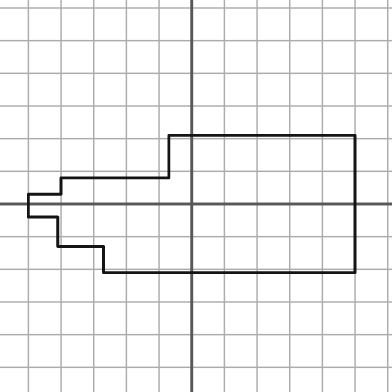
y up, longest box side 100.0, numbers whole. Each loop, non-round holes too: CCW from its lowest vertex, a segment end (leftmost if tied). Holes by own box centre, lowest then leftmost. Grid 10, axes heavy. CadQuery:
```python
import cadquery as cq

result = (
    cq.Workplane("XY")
    .moveTo(-27.0, -21.0)
    .lineTo(50.0, -21.0)
    .lineTo(50.0, 21.0)
    .lineTo(-7.0, 21.0)
    .lineTo(-7.0, 8.0)
    .lineTo(-40.0, 8.0)
    .lineTo(-40.0, 3.0)
    .lineTo(-50.0, 3.0)
    .lineTo(-50.0, -4.0)
    .lineTo(-41.0, -4.0)
    .lineTo(-41.0, -13.0)
    .lineTo(-27.0, -13.0)
    .close()
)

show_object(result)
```